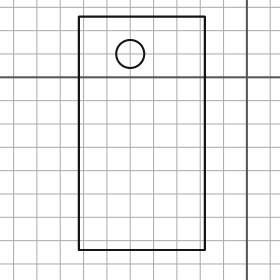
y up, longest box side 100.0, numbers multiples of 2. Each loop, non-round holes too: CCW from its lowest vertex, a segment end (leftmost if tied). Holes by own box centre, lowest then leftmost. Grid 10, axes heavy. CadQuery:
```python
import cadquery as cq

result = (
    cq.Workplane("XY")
    .moveTo(-72.0, -74.0)
    .lineTo(-18.0, -74.0)
    .lineTo(-18.0, 26.0)
    .lineTo(-72.0, 26.0)
    .close()
    .moveTo(-50.0, 10.0)
    .circle(6.0)
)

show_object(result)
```